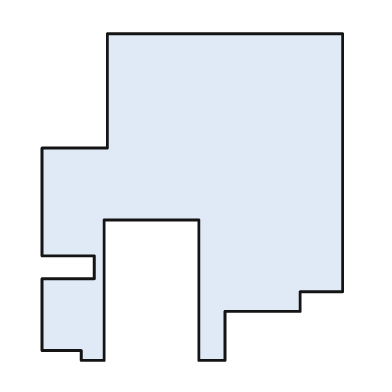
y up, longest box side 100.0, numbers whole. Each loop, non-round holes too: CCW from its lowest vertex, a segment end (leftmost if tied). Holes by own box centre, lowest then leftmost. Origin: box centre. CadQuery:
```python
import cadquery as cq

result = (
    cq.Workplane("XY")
    .moveTo(-34.0, -50.0)
    .lineTo(-27.0, -50.0)
    .lineTo(-27.0, -7.0)
    .lineTo(2.0, -7.0)
    .lineTo(2.0, -50.0)
    .lineTo(10.0, -50.0)
    .lineTo(10.0, -35.0)
    .lineTo(33.0, -35.0)
    .lineTo(33.0, -29.0)
    .lineTo(46.0, -29.0)
    .lineTo(46.0, 50.0)
    .lineTo(-26.0, 50.0)
    .lineTo(-26.0, 15.0)
    .lineTo(-46.0, 15.0)
    .lineTo(-46.0, -18.0)
    .lineTo(-30.0, -18.0)
    .lineTo(-30.0, -25.0)
    .lineTo(-46.0, -25.0)
    .lineTo(-46.0, -47.0)
    .lineTo(-34.0, -47.0)
    .close()
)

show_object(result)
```